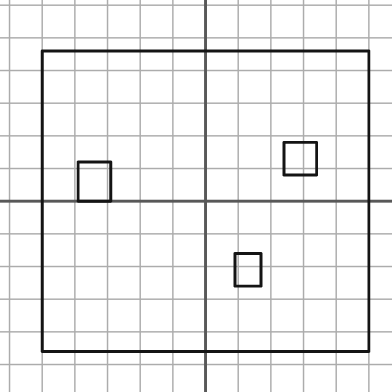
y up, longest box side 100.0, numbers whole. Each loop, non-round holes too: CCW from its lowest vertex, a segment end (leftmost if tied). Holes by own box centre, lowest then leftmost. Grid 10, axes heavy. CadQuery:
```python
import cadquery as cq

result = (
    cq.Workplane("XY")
    .moveTo(-50.0, -46.0)
    .lineTo(50.0, -46.0)
    .lineTo(50.0, 46.0)
    .lineTo(-50.0, 46.0)
    .close()
    .moveTo(9.0, -26.0)
    .lineTo(17.0, -26.0)
    .lineTo(17.0, -16.0)
    .lineTo(9.0, -16.0)
    .close()
    .moveTo(-39.0, 0.0)
    .lineTo(-29.0, 0.0)
    .lineTo(-29.0, 12.0)
    .lineTo(-39.0, 12.0)
    .close()
    .moveTo(24.0, 8.0)
    .lineTo(34.0, 8.0)
    .lineTo(34.0, 18.0)
    .lineTo(24.0, 18.0)
    .close()
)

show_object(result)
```